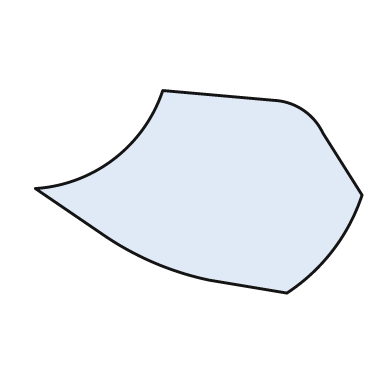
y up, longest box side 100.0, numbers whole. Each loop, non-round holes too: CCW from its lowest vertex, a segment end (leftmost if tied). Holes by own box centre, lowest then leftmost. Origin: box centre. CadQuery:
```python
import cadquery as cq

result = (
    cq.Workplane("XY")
    .moveTo(27.0, -31.0)
    .threePointArc((41.0, -18.0), (50.0, -1.0))
    .lineTo(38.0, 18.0)
    .threePointArc((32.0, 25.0), (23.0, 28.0))
    .lineTo(-11.0, 31.0)
    .threePointArc((-26.0, 10.0), (-50.0, 1.0))
    .lineTo(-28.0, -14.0)
    .threePointArc((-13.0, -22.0), (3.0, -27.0))
    .close()
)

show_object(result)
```